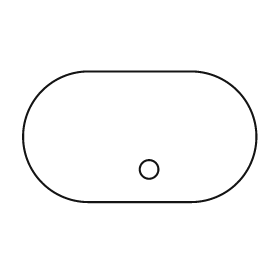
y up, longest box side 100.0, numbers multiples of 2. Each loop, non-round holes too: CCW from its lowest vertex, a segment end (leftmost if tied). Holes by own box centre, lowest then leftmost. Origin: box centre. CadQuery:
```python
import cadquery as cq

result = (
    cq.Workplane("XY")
    .moveTo(-22.0, -28.0)
    .lineTo(22.0, -28.0)
    .threePointArc((50.0, 0.0), (22.0, 28.0))
    .lineTo(-22.0, 28.0)
    .threePointArc((-50.0, 0.0), (-22.0, -28.0))
    .close()
    .moveTo(4.0, -14.0)
    .circle(4.0)
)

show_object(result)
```